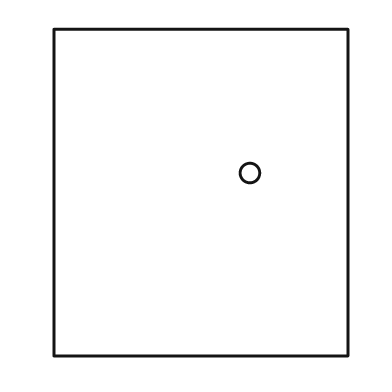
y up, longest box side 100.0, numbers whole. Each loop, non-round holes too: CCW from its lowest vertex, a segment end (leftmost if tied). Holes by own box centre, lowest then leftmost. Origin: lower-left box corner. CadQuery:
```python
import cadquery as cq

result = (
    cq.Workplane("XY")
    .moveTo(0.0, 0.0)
    .lineTo(90.0, 0.0)
    .lineTo(90.0, 100.0)
    .lineTo(0.0, 100.0)
    .close()
    .moveTo(60.0, 56.0)
    .circle(3.0)
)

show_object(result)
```